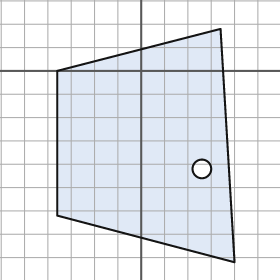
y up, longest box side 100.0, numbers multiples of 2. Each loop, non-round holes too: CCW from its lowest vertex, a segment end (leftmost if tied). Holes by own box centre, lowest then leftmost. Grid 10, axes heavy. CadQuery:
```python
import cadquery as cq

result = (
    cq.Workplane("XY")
    .moveTo(40.0, -82.0)
    .lineTo(34.0, 18.0)
    .lineTo(-36.0, 0.0)
    .lineTo(-36.0, -62.0)
    .close()
    .moveTo(26.0, -42.0)
    .circle(4.0)
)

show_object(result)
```